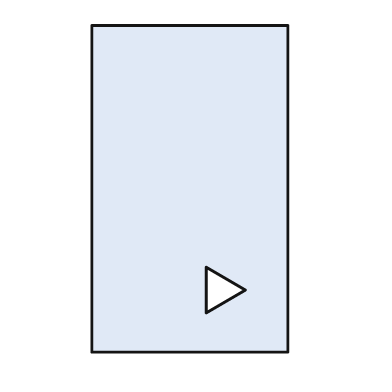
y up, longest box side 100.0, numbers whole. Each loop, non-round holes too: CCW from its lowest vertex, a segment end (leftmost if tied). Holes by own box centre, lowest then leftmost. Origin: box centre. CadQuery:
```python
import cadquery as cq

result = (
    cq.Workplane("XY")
    .moveTo(-30.0, -50.0)
    .lineTo(30.0, -50.0)
    .lineTo(30.0, 50.0)
    .lineTo(-30.0, 50.0)
    .close()
    .moveTo(5.0, -38.0)
    .lineTo(17.0, -31.0)
    .lineTo(5.0, -24.0)
    .close()
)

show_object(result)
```